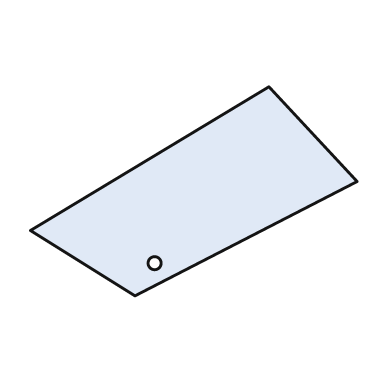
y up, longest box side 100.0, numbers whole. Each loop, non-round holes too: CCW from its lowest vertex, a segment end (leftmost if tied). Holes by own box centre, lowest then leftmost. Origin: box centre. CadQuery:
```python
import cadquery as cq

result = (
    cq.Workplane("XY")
    .moveTo(-18.0, -32.0)
    .lineTo(50.0, 3.0)
    .lineTo(23.0, 32.0)
    .lineTo(-50.0, -12.0)
    .close()
    .moveTo(-12.0, -22.0)
    .circle(2.0)
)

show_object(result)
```